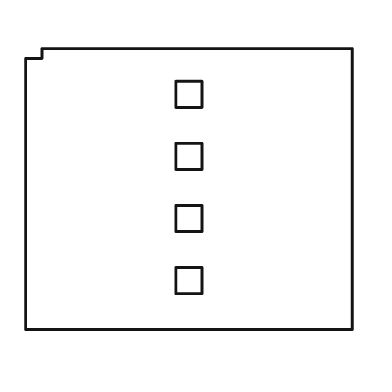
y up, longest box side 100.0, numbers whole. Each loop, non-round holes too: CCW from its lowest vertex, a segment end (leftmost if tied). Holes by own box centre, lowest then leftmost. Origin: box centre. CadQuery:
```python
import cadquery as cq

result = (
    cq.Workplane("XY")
    .moveTo(-50.0, -43.0)
    .lineTo(50.0, -43.0)
    .lineTo(50.0, 43.0)
    .lineTo(-45.0, 43.0)
    .lineTo(-45.0, 40.0)
    .lineTo(-50.0, 40.0)
    .close()
    .moveTo(-4.0, -32.0)
    .lineTo(4.0, -32.0)
    .lineTo(4.0, -24.0)
    .lineTo(-4.0, -24.0)
    .close()
    .moveTo(-4.0, -13.0)
    .lineTo(4.0, -13.0)
    .lineTo(4.0, -5.0)
    .lineTo(-4.0, -5.0)
    .close()
    .moveTo(-4.0, 6.0)
    .lineTo(4.0, 6.0)
    .lineTo(4.0, 14.0)
    .lineTo(-4.0, 14.0)
    .close()
    .moveTo(-4.0, 25.0)
    .lineTo(4.0, 25.0)
    .lineTo(4.0, 33.0)
    .lineTo(-4.0, 33.0)
    .close()
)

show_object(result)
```